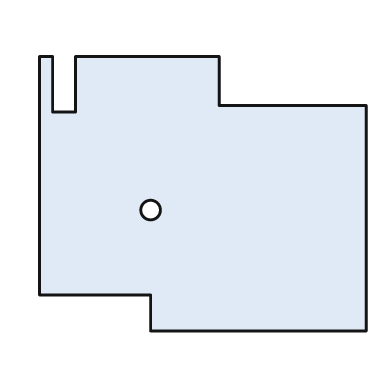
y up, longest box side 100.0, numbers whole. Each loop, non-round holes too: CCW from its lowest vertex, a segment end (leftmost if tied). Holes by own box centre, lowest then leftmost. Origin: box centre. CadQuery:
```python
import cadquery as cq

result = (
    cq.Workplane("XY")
    .moveTo(-16.0, -42.0)
    .lineTo(50.0, -42.0)
    .lineTo(50.0, 27.0)
    .lineTo(5.0, 27.0)
    .lineTo(5.0, 42.0)
    .lineTo(-39.0, 42.0)
    .lineTo(-39.0, 25.0)
    .lineTo(-46.0, 25.0)
    .lineTo(-46.0, 42.0)
    .lineTo(-50.0, 42.0)
    .lineTo(-50.0, -31.0)
    .lineTo(-16.0, -31.0)
    .close()
    .moveTo(-16.0, -5.0)
    .circle(3.0)
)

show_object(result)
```